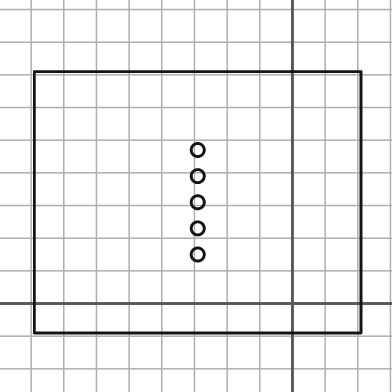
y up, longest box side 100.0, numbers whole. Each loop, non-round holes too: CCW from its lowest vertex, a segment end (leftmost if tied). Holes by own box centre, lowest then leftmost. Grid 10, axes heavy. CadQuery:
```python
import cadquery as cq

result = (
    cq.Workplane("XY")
    .moveTo(-79.0, -9.0)
    .lineTo(21.0, -9.0)
    .lineTo(21.0, 71.0)
    .lineTo(-79.0, 71.0)
    .close()
    .moveTo(-29.0, 15.0)
    .circle(2.0)
    .moveTo(-29.0, 23.0)
    .circle(2.0)
    .moveTo(-29.0, 31.0)
    .circle(2.0)
    .moveTo(-29.0, 39.0)
    .circle(2.0)
    .moveTo(-29.0, 47.0)
    .circle(2.0)
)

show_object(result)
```